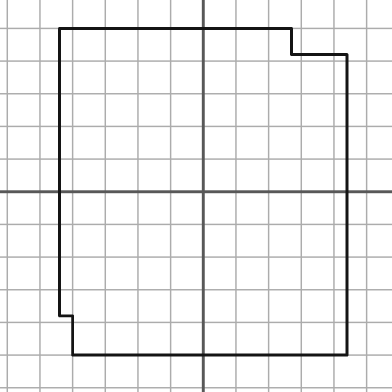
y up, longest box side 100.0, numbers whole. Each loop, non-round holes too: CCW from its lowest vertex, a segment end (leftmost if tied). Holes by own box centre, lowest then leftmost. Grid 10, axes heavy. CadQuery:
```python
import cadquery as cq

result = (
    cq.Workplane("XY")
    .moveTo(-40.0, -50.0)
    .lineTo(44.0, -50.0)
    .lineTo(44.0, 42.0)
    .lineTo(27.0, 42.0)
    .lineTo(27.0, 50.0)
    .lineTo(-44.0, 50.0)
    .lineTo(-44.0, -38.0)
    .lineTo(-40.0, -38.0)
    .close()
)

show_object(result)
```